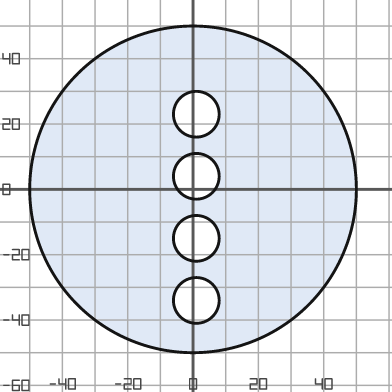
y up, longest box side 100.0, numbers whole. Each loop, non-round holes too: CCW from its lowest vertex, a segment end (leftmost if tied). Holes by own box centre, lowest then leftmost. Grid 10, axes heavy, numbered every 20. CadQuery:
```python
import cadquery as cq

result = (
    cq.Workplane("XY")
    .moveTo(0.0, 0.0)
    .circle(50.0)
    .moveTo(1.0, -34.0)
    .circle(7.0)
    .moveTo(1.0, -15.0)
    .circle(7.0)
    .moveTo(1.0, 4.0)
    .circle(7.0)
    .moveTo(1.0, 23.0)
    .circle(7.0)
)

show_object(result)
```